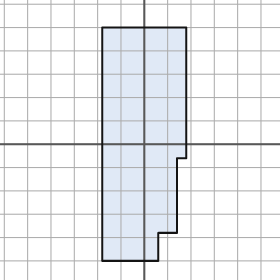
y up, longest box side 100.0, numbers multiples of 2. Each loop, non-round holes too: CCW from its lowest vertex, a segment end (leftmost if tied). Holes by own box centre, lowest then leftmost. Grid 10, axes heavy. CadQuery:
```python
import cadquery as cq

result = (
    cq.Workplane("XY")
    .moveTo(-18.0, -50.0)
    .lineTo(6.0, -50.0)
    .lineTo(6.0, -38.0)
    .lineTo(14.0, -38.0)
    .lineTo(14.0, -6.0)
    .lineTo(18.0, -6.0)
    .lineTo(18.0, 50.0)
    .lineTo(-18.0, 50.0)
    .close()
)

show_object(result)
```